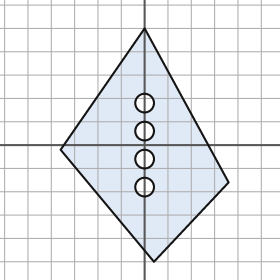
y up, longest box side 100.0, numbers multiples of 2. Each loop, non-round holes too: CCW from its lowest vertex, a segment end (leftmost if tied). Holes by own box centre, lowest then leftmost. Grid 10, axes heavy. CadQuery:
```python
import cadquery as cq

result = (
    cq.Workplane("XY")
    .moveTo(4.0, -50.0)
    .lineTo(36.0, -16.0)
    .lineTo(0.0, 50.0)
    .lineTo(-36.0, -2.0)
    .close()
    .moveTo(0.0, -18.0)
    .circle(4.0)
    .moveTo(0.0, -6.0)
    .circle(4.0)
    .moveTo(0.0, 6.0)
    .circle(4.0)
    .moveTo(0.0, 18.0)
    .circle(4.0)
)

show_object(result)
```